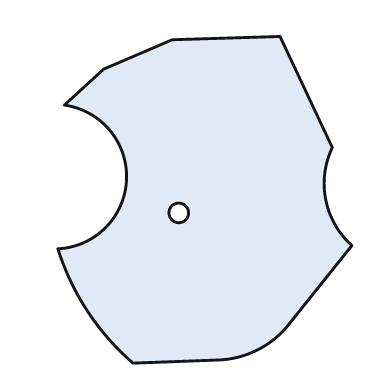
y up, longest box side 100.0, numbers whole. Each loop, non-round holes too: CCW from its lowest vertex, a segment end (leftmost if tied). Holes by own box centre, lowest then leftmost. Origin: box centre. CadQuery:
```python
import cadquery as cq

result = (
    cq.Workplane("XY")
    .moveTo(-22.0, -50.0)
    .lineTo(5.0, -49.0)
    .threePointArc((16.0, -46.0), (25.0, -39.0))
    .lineTo(45.0, -14.0)
    .threePointArc((37.0, 0.0), (39.0, 16.0))
    .lineTo(23.0, 50.0)
    .lineTo(-10.0, 49.0)
    .lineTo(-31.0, 40.0)
    .lineTo(-43.0, 29.0)
    .threePointArc((-24.0, 6.0), (-45.0, -15.0))
    .threePointArc((-36.0, -34.0), (-22.0, -50.0))
    .close()
    .moveTo(-8.0, -4.0)
    .circle(3.0)
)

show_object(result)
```